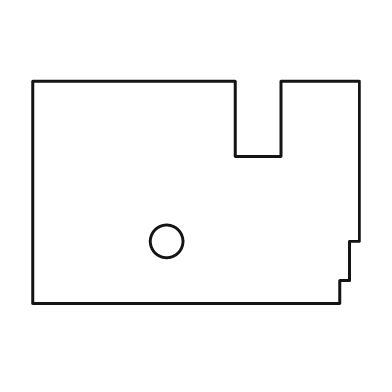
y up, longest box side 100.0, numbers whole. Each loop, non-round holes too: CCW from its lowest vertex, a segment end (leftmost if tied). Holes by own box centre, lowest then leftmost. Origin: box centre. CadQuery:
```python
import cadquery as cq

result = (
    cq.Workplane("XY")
    .moveTo(-50.0, -34.0)
    .lineTo(44.0, -34.0)
    .lineTo(44.0, -27.0)
    .lineTo(47.0, -27.0)
    .lineTo(47.0, -15.0)
    .lineTo(50.0, -15.0)
    .lineTo(50.0, 34.0)
    .lineTo(26.0, 34.0)
    .lineTo(26.0, 11.0)
    .lineTo(12.0, 11.0)
    .lineTo(12.0, 34.0)
    .lineTo(-50.0, 34.0)
    .close()
    .moveTo(-9.0, -15.0)
    .circle(5.0)
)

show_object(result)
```